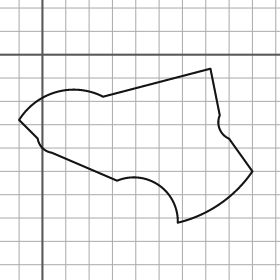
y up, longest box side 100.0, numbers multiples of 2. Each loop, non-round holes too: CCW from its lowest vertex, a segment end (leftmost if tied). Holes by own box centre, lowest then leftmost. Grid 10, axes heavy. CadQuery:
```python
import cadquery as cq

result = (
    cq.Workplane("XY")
    .moveTo(58.0, -72.0)
    .threePointArc((76.0, -64.0), (90.0, -50.0))
    .lineTo(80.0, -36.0)
    .threePointArc((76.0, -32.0), (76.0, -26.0))
    .lineTo(72.0, -6.0)
    .lineTo(26.0, -18.0)
    .threePointArc((6.0, -16.0), (-10.0, -28.0))
    .lineTo(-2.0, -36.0)
    .threePointArc((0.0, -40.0), (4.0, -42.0))
    .lineTo(32.0, -54.0)
    .threePointArc((50.0, -56.0), (58.0, -72.0))
    .close()
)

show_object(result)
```